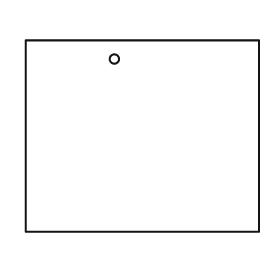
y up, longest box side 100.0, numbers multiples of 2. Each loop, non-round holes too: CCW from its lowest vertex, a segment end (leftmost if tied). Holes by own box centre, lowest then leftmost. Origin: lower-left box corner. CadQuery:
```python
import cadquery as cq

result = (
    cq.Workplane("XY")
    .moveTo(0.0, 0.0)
    .lineTo(100.0, 0.0)
    .lineTo(100.0, 82.0)
    .lineTo(0.0, 82.0)
    .close()
    .moveTo(38.0, 74.0)
    .circle(2.0)
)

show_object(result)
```